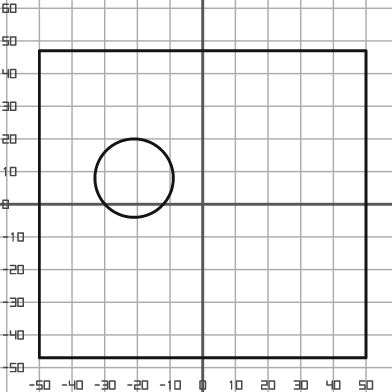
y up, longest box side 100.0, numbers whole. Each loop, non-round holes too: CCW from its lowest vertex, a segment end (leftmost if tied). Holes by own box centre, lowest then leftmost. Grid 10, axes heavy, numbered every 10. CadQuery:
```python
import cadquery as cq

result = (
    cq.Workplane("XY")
    .moveTo(-50.0, -47.0)
    .lineTo(50.0, -47.0)
    .lineTo(50.0, 47.0)
    .lineTo(-50.0, 47.0)
    .close()
    .moveTo(-21.0, 8.0)
    .circle(12.0)
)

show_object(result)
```